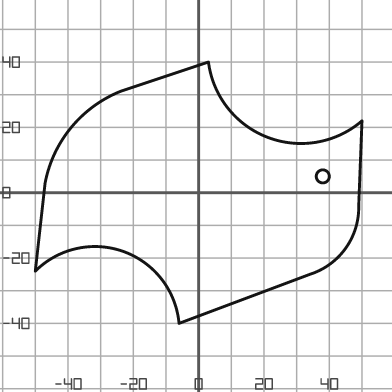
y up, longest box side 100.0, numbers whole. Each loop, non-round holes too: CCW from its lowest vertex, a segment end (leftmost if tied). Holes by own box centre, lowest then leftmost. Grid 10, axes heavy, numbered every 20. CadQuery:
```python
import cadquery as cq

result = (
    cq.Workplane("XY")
    .moveTo(-6.0, -40.0)
    .lineTo(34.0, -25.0)
    .threePointArc((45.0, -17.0), (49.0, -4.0))
    .lineTo(50.0, 22.0)
    .threePointArc((21.0, 17.0), (3.0, 40.0))
    .lineTo(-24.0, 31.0)
    .threePointArc((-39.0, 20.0), (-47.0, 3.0))
    .lineTo(-50.0, -24.0)
    .threePointArc((-23.0, -18.0), (-6.0, -40.0))
    .close()
    .moveTo(38.0, 5.0)
    .circle(2.0)
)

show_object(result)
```